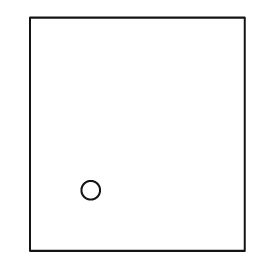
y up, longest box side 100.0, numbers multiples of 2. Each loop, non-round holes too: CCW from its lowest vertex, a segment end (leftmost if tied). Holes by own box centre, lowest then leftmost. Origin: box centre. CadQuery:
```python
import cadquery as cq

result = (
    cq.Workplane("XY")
    .moveTo(-46.0, -50.0)
    .lineTo(46.0, -50.0)
    .lineTo(46.0, 50.0)
    .lineTo(-46.0, 50.0)
    .close()
    .moveTo(-20.0, -24.0)
    .circle(4.0)
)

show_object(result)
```